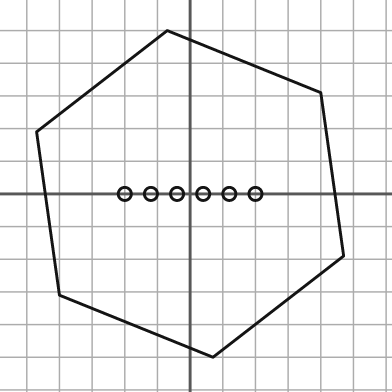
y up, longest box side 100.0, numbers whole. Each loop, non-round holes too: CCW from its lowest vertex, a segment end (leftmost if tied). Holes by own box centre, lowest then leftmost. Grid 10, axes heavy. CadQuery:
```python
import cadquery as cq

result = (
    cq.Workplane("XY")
    .moveTo(7.0, -50.0)
    .lineTo(47.0, -19.0)
    .lineTo(40.0, 31.0)
    .lineTo(-7.0, 50.0)
    .lineTo(-47.0, 19.0)
    .lineTo(-40.0, -31.0)
    .close()
    .moveTo(-20.0, 0.0)
    .circle(2.0)
    .moveTo(-12.0, 0.0)
    .circle(2.0)
    .moveTo(-4.0, 0.0)
    .circle(2.0)
    .moveTo(4.0, 0.0)
    .circle(2.0)
    .moveTo(12.0, 0.0)
    .circle(2.0)
    .moveTo(20.0, 0.0)
    .circle(2.0)
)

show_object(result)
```